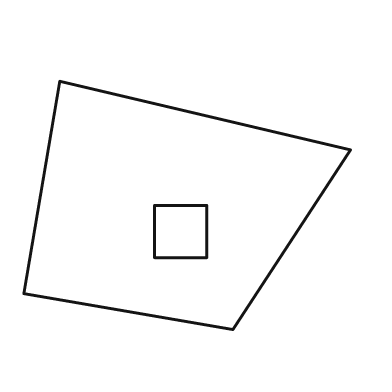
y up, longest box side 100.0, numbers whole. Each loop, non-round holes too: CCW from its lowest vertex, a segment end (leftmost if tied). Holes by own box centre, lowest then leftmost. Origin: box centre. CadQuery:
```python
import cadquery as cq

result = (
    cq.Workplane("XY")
    .moveTo(14.0, -38.0)
    .lineTo(50.0, 17.0)
    .lineTo(-39.0, 38.0)
    .lineTo(-50.0, -27.0)
    .close()
    .moveTo(-10.0, -16.0)
    .lineTo(6.0, -16.0)
    .lineTo(6.0, 0.0)
    .lineTo(-10.0, 0.0)
    .close()
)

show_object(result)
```